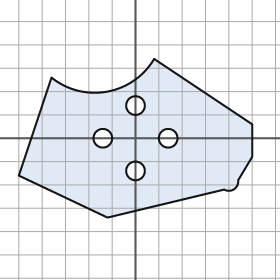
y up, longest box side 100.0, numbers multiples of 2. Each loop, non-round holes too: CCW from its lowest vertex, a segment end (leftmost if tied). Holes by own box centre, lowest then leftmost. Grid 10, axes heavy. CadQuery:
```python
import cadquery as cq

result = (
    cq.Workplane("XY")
    .moveTo(-12.0, -34.0)
    .lineTo(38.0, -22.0)
    .threePointArc((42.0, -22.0), (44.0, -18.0))
    .lineTo(50.0, -8.0)
    .lineTo(50.0, 6.0)
    .lineTo(8.0, 34.0)
    .threePointArc((-12.0, 20.0), (-36.0, 26.0))
    .lineTo(-50.0, -16.0)
    .close()
    .moveTo(0.0, -14.0)
    .circle(4.0)
    .moveTo(-14.0, 0.0)
    .circle(4.0)
    .moveTo(14.0, 0.0)
    .circle(4.0)
    .moveTo(0.0, 14.0)
    .circle(4.0)
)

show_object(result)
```